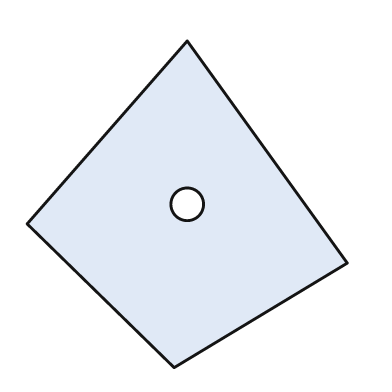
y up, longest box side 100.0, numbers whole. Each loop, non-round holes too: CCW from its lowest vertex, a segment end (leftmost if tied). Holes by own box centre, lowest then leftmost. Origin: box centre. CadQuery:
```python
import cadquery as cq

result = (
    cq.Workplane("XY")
    .moveTo(-4.0, -50.0)
    .lineTo(49.0, -18.0)
    .lineTo(0.0, 50.0)
    .lineTo(-49.0, -6.0)
    .close()
    .moveTo(0.0, 0.0)
    .circle(5.0)
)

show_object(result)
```